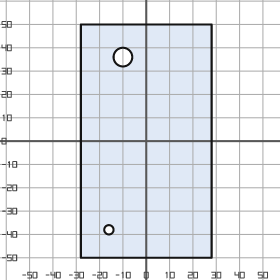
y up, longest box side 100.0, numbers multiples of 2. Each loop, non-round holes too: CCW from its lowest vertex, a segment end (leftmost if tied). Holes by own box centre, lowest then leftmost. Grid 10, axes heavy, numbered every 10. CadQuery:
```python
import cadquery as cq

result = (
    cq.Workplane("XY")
    .moveTo(-28.0, -50.0)
    .lineTo(28.0, -50.0)
    .lineTo(28.0, 50.0)
    .lineTo(-28.0, 50.0)
    .close()
    .moveTo(-16.0, -38.0)
    .circle(2.0)
    .moveTo(-10.0, 36.0)
    .circle(4.0)
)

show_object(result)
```